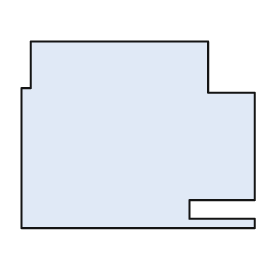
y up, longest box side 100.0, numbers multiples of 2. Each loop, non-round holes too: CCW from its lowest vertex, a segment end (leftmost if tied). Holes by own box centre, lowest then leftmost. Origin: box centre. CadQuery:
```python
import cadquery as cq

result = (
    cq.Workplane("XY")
    .moveTo(-50.0, -40.0)
    .lineTo(50.0, -40.0)
    .lineTo(50.0, -36.0)
    .lineTo(22.0, -36.0)
    .lineTo(22.0, -28.0)
    .lineTo(50.0, -28.0)
    .lineTo(50.0, 18.0)
    .lineTo(30.0, 18.0)
    .lineTo(30.0, 40.0)
    .lineTo(-46.0, 40.0)
    .lineTo(-46.0, 20.0)
    .lineTo(-50.0, 20.0)
    .close()
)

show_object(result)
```